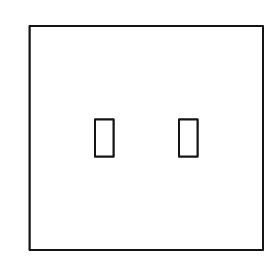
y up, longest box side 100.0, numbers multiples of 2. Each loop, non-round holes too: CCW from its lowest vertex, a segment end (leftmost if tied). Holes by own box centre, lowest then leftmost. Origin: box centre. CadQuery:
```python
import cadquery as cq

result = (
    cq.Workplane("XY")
    .moveTo(-50.0, -48.0)
    .lineTo(50.0, -48.0)
    .lineTo(50.0, 48.0)
    .lineTo(-50.0, 48.0)
    .close()
    .moveTo(-22.0, -8.0)
    .lineTo(-14.0, -8.0)
    .lineTo(-14.0, 8.0)
    .lineTo(-22.0, 8.0)
    .close()
    .moveTo(14.0, -8.0)
    .lineTo(22.0, -8.0)
    .lineTo(22.0, 8.0)
    .lineTo(14.0, 8.0)
    .close()
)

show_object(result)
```